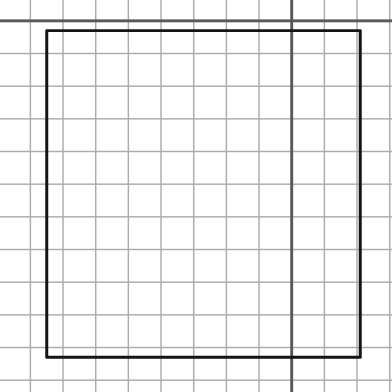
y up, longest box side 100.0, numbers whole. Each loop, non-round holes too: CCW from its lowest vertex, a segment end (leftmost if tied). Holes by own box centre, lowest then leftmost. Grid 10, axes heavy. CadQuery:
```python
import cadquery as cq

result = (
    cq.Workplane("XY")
    .moveTo(-75.0, -103.0)
    .lineTo(21.0, -103.0)
    .lineTo(21.0, -3.0)
    .lineTo(-75.0, -3.0)
    .close()
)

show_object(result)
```